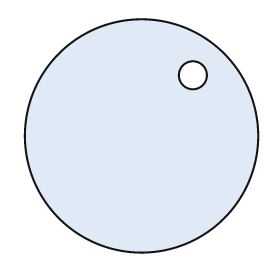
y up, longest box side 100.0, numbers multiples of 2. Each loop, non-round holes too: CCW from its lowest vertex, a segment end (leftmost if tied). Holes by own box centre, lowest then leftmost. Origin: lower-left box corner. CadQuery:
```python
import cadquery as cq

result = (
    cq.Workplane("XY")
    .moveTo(50.0, 50.0)
    .circle(50.0)
    .moveTo(72.0, 76.0)
    .circle(6.0)
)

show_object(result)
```